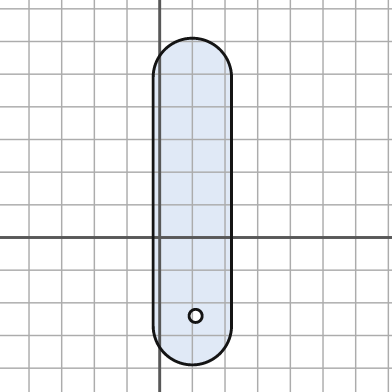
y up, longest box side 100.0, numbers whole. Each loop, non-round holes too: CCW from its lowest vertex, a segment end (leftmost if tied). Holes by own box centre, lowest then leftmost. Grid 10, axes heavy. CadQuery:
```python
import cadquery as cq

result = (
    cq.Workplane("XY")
    .moveTo(-2.0, -27.0)
    .threePointArc((10.0, -39.0), (22.0, -27.0))
    .lineTo(22.0, 49.0)
    .threePointArc((10.0, 61.0), (-2.0, 49.0))
    .close()
    .moveTo(11.0, -24.0)
    .circle(2.0)
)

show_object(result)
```